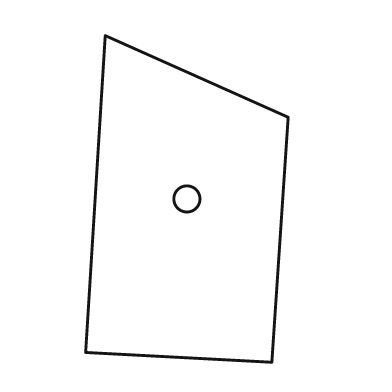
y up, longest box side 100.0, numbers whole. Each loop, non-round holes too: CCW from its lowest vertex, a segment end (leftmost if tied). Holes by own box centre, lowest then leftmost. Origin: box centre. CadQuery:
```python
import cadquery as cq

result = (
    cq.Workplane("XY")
    .moveTo(26.0, -50.0)
    .lineTo(31.0, 25.0)
    .lineTo(-25.0, 50.0)
    .lineTo(-31.0, -47.0)
    .close()
    .moveTo(0.0, 0.0)
    .circle(4.0)
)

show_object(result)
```